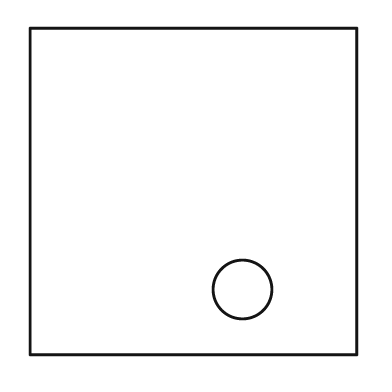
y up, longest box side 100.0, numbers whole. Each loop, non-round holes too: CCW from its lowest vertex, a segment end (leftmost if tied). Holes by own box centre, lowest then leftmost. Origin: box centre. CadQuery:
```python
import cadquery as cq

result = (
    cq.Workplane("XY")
    .moveTo(-50.0, -50.0)
    .lineTo(50.0, -50.0)
    .lineTo(50.0, 50.0)
    .lineTo(-50.0, 50.0)
    .close()
    .moveTo(15.0, -30.0)
    .circle(9.0)
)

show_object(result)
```